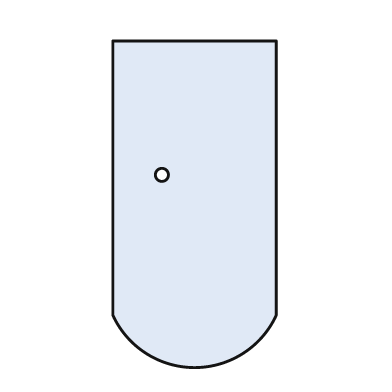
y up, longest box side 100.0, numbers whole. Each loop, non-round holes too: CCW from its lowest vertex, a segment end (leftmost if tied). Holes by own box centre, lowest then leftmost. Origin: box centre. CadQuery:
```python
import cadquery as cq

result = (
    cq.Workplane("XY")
    .moveTo(-25.0, -34.0)
    .threePointArc((0.0, -50.0), (25.0, -34.0))
    .lineTo(25.0, 50.0)
    .lineTo(-25.0, 50.0)
    .close()
    .moveTo(-10.0, 9.0)
    .circle(2.0)
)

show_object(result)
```